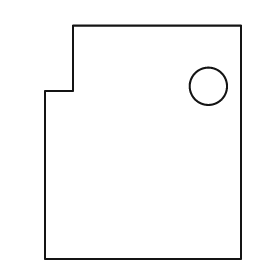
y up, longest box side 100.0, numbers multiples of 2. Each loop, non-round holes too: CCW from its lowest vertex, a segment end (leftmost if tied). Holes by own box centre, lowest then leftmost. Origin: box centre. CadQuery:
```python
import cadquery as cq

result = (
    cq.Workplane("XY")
    .moveTo(-42.0, -50.0)
    .lineTo(42.0, -50.0)
    .lineTo(42.0, 50.0)
    .lineTo(-30.0, 50.0)
    .lineTo(-30.0, 22.0)
    .lineTo(-42.0, 22.0)
    .close()
    .moveTo(28.0, 24.0)
    .circle(8.0)
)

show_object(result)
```